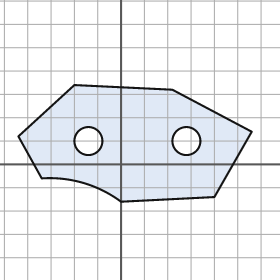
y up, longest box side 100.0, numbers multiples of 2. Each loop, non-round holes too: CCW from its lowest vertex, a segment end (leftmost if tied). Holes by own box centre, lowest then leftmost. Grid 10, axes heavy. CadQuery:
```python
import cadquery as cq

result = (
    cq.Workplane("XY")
    .moveTo(0.0, -16.0)
    .lineTo(40.0, -14.0)
    .lineTo(56.0, 14.0)
    .lineTo(22.0, 32.0)
    .lineTo(-20.0, 34.0)
    .lineTo(-44.0, 12.0)
    .lineTo(-34.0, -6.0)
    .threePointArc((-16.0, -8.0), (0.0, -16.0))
    .close()
    .moveTo(-14.0, 10.0)
    .circle(6.0)
    .moveTo(28.0, 10.0)
    .circle(6.0)
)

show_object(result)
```